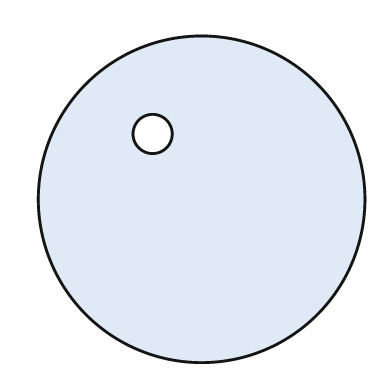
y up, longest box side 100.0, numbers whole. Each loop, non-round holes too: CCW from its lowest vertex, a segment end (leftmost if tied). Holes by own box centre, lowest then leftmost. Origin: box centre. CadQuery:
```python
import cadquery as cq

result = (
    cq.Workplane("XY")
    .moveTo(0.0, 0.0)
    .circle(50.0)
    .moveTo(-15.0, 20.0)
    .circle(6.0)
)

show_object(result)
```